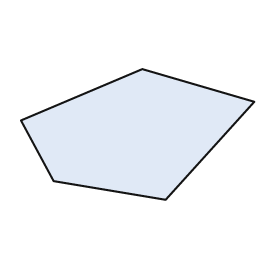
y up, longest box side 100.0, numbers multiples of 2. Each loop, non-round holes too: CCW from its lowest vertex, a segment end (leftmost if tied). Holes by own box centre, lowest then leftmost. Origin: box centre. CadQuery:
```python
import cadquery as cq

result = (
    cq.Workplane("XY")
    .moveTo(12.0, -28.0)
    .lineTo(50.0, 14.0)
    .lineTo(2.0, 28.0)
    .lineTo(-50.0, 6.0)
    .lineTo(-36.0, -20.0)
    .close()
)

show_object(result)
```